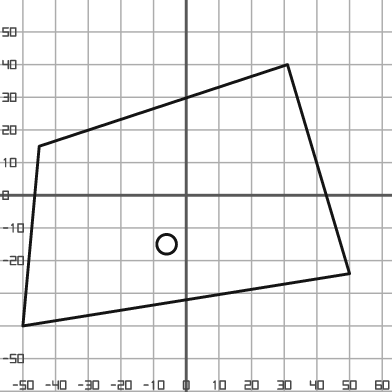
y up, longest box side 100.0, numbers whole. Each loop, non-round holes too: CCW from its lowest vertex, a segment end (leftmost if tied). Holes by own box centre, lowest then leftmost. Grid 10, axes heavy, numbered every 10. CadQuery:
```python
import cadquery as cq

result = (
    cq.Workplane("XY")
    .moveTo(-50.0, -40.0)
    .lineTo(50.0, -24.0)
    .lineTo(31.0, 40.0)
    .lineTo(-45.0, 15.0)
    .close()
    .moveTo(-6.0, -15.0)
    .circle(3.0)
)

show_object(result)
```